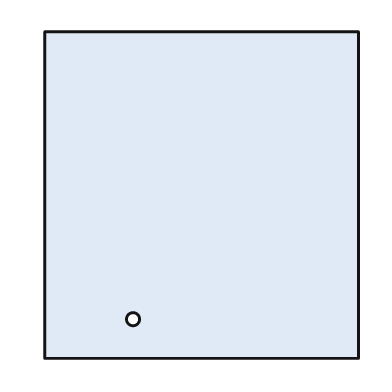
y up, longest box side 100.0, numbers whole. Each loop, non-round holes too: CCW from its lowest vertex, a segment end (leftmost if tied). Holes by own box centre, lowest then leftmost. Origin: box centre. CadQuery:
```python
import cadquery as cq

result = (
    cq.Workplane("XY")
    .moveTo(-48.0, -50.0)
    .lineTo(48.0, -50.0)
    .lineTo(48.0, 50.0)
    .lineTo(-48.0, 50.0)
    .close()
    .moveTo(-21.0, -38.0)
    .circle(2.0)
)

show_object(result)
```